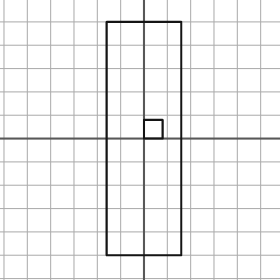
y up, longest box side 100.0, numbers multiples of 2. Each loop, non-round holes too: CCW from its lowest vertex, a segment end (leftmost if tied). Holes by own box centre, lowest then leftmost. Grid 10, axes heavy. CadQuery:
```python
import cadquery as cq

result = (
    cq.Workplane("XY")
    .moveTo(-16.0, -50.0)
    .lineTo(16.0, -50.0)
    .lineTo(16.0, 50.0)
    .lineTo(-16.0, 50.0)
    .close()
    .moveTo(0.0, 0.0)
    .lineTo(8.0, 0.0)
    .lineTo(8.0, 8.0)
    .lineTo(0.0, 8.0)
    .close()
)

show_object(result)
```